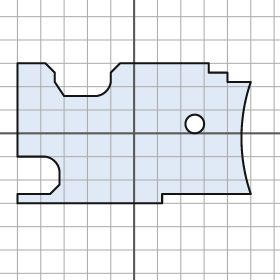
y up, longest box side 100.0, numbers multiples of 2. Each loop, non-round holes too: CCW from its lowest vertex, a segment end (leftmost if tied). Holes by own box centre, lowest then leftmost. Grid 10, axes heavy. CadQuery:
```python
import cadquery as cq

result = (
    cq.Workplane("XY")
    .moveTo(-50.0, -30.0)
    .lineTo(12.0, -30.0)
    .lineTo(12.0, -26.0)
    .lineTo(50.0, -26.0)
    .threePointArc((46.0, -2.0), (50.0, 22.0))
    .lineTo(40.0, 22.0)
    .lineTo(40.0, 26.0)
    .lineTo(32.0, 26.0)
    .lineTo(32.0, 30.0)
    .lineTo(-6.0, 30.0)
    .lineTo(-10.0, 26.0)
    .lineTo(-10.0, 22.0)
    .threePointArc((-12.0, 18.0), (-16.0, 16.0))
    .lineTo(-30.0, 16.0)
    .lineTo(-34.0, 22.0)
    .lineTo(-34.0, 26.0)
    .lineTo(-38.0, 30.0)
    .lineTo(-50.0, 30.0)
    .lineTo(-50.0, -10.0)
    .lineTo(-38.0, -10.0)
    .threePointArc((-34.0, -12.0), (-32.0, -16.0))
    .lineTo(-32.0, -22.0)
    .lineTo(-36.0, -26.0)
    .lineTo(-50.0, -26.0)
    .close()
    .moveTo(26.0, 4.0)
    .circle(4.0)
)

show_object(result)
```